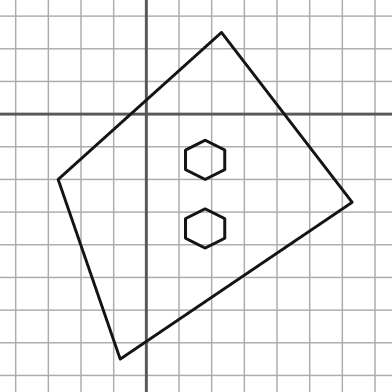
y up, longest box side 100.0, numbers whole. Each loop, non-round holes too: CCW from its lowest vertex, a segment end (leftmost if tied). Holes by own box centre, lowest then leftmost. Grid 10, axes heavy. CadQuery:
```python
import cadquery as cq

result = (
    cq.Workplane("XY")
    .moveTo(-8.0, -75.0)
    .lineTo(63.0, -27.0)
    .lineTo(23.0, 25.0)
    .lineTo(-27.0, -20.0)
    .close()
    .moveTo(18.0, -41.0)
    .lineTo(24.0, -38.0)
    .lineTo(24.0, -32.0)
    .lineTo(18.0, -29.0)
    .lineTo(12.0, -32.0)
    .lineTo(12.0, -38.0)
    .close()
    .moveTo(18.0, -20.0)
    .lineTo(24.0, -17.0)
    .lineTo(24.0, -11.0)
    .lineTo(18.0, -8.0)
    .lineTo(12.0, -11.0)
    .lineTo(12.0, -17.0)
    .close()
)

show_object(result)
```